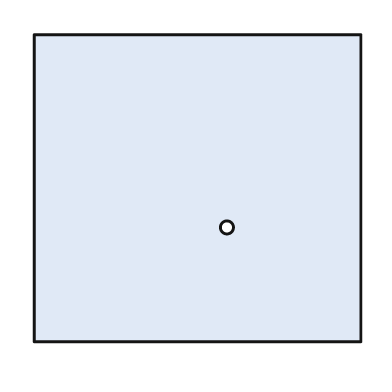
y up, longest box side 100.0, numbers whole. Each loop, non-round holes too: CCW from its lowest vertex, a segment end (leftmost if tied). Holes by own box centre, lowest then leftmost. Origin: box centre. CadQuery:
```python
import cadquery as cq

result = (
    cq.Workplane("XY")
    .moveTo(-50.0, -47.0)
    .lineTo(50.0, -47.0)
    .lineTo(50.0, 47.0)
    .lineTo(-50.0, 47.0)
    .close()
    .moveTo(9.0, -12.0)
    .circle(2.0)
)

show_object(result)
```